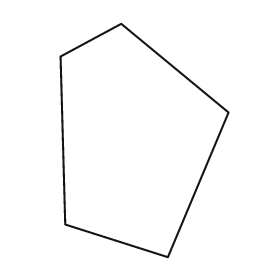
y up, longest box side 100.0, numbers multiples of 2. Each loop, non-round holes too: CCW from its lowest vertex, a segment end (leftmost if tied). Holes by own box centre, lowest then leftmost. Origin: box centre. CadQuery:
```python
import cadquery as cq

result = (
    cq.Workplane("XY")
    .moveTo(10.0, -50.0)
    .lineTo(36.0, 12.0)
    .lineTo(-10.0, 50.0)
    .lineTo(-36.0, 36.0)
    .lineTo(-34.0, -36.0)
    .close()
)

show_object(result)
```